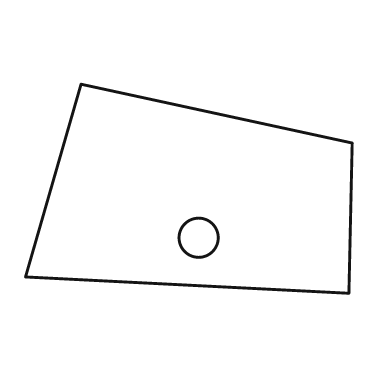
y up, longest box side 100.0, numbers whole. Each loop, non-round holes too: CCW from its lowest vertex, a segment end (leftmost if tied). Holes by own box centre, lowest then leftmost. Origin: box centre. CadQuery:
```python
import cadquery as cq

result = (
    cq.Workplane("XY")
    .moveTo(49.0, -32.0)
    .lineTo(50.0, 14.0)
    .lineTo(-33.0, 32.0)
    .lineTo(-50.0, -27.0)
    .close()
    .moveTo(3.0, -15.0)
    .circle(6.0)
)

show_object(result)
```